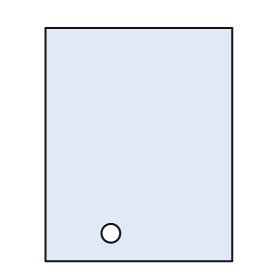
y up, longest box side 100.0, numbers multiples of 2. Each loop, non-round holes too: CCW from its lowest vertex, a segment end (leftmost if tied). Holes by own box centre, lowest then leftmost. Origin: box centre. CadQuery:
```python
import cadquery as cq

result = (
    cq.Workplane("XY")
    .moveTo(-40.0, -50.0)
    .lineTo(40.0, -50.0)
    .lineTo(40.0, 50.0)
    .lineTo(-40.0, 50.0)
    .close()
    .moveTo(-12.0, -38.0)
    .circle(4.0)
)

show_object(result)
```